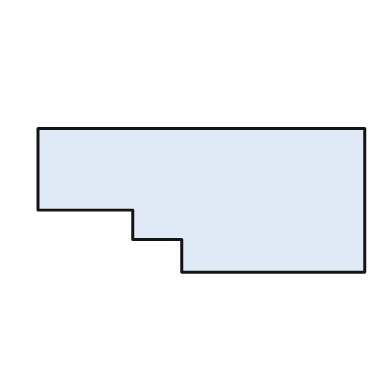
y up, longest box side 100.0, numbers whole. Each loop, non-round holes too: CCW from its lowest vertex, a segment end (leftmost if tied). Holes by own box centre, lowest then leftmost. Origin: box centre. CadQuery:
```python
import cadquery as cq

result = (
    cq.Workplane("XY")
    .moveTo(-6.0, -22.0)
    .lineTo(50.0, -22.0)
    .lineTo(50.0, 22.0)
    .lineTo(-50.0, 22.0)
    .lineTo(-50.0, -3.0)
    .lineTo(-21.0, -3.0)
    .lineTo(-21.0, -12.0)
    .lineTo(-6.0, -12.0)
    .close()
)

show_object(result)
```